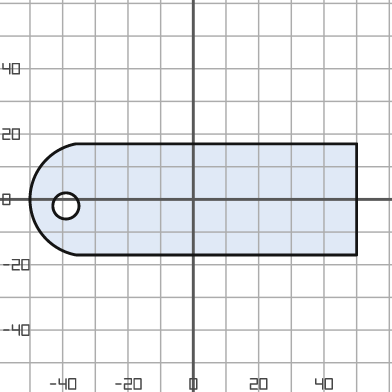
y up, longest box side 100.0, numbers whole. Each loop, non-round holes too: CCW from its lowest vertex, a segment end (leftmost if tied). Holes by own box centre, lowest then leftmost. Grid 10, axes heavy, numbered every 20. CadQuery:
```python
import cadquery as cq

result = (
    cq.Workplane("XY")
    .moveTo(-36.0, -17.0)
    .lineTo(50.0, -17.0)
    .lineTo(50.0, 17.0)
    .lineTo(-36.0, 17.0)
    .threePointArc((-50.0, 0.0), (-36.0, -17.0))
    .close()
    .moveTo(-39.0, -2.0)
    .circle(4.0)
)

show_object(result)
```